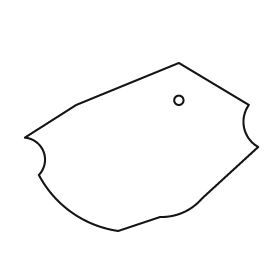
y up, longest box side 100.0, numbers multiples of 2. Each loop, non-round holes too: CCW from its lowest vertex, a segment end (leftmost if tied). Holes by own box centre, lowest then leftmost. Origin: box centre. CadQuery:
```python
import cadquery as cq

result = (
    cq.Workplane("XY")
    .moveTo(-10.0, -36.0)
    .lineTo(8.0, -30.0)
    .threePointArc((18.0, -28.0), (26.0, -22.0))
    .lineTo(50.0, 0.0)
    .threePointArc((44.0, 8.0), (46.0, 18.0))
    .lineTo(16.0, 36.0)
    .lineTo(-28.0, 18.0)
    .lineTo(-50.0, 4.0)
    .threePointArc((-42.0, -2.0), (-44.0, -12.0))
    .threePointArc((-30.0, -28.0), (-10.0, -36.0))
    .close()
    .moveTo(16.0, 20.0)
    .circle(2.0)
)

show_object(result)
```